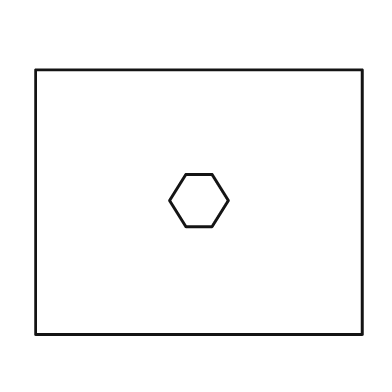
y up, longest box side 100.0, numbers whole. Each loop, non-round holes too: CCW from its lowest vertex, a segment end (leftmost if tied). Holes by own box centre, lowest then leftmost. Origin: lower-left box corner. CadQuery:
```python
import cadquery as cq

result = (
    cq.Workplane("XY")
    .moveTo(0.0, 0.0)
    .lineTo(100.0, 0.0)
    .lineTo(100.0, 81.0)
    .lineTo(0.0, 81.0)
    .close()
    .moveTo(46.0, 33.0)
    .lineTo(54.0, 33.0)
    .lineTo(59.0, 41.0)
    .lineTo(54.0, 49.0)
    .lineTo(46.0, 49.0)
    .lineTo(41.0, 41.0)
    .close()
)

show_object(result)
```